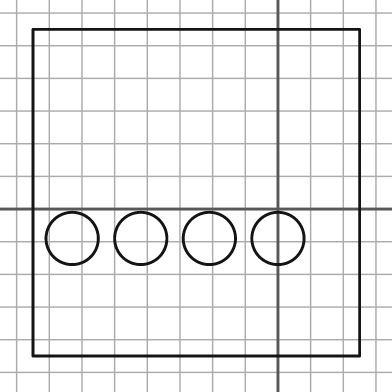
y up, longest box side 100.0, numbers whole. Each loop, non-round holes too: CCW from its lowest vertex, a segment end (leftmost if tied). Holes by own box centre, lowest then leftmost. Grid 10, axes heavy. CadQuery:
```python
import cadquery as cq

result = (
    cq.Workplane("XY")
    .moveTo(-75.0, -45.0)
    .lineTo(25.0, -45.0)
    .lineTo(25.0, 55.0)
    .lineTo(-75.0, 55.0)
    .close()
    .moveTo(-63.0, -9.0)
    .circle(8.0)
    .moveTo(-42.0, -9.0)
    .circle(8.0)
    .moveTo(-21.0, -9.0)
    .circle(8.0)
    .moveTo(0.0, -9.0)
    .circle(8.0)
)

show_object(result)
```